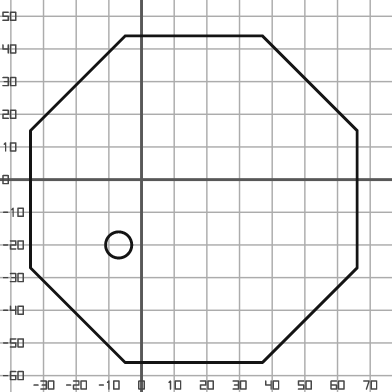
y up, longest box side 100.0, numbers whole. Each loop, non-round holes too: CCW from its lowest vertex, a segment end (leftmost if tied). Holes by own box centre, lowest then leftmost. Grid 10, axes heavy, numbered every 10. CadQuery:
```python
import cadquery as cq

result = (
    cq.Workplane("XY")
    .moveTo(-5.0, -56.0)
    .lineTo(37.0, -56.0)
    .lineTo(66.0, -27.0)
    .lineTo(66.0, 15.0)
    .lineTo(37.0, 44.0)
    .lineTo(-5.0, 44.0)
    .lineTo(-34.0, 15.0)
    .lineTo(-34.0, -27.0)
    .close()
    .moveTo(-7.0, -20.0)
    .circle(4.0)
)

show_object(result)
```